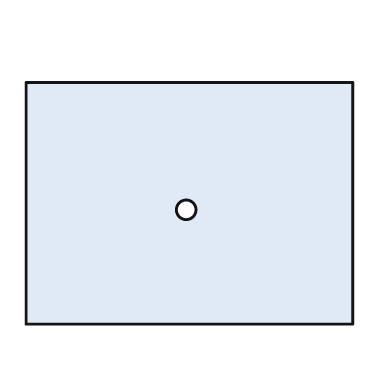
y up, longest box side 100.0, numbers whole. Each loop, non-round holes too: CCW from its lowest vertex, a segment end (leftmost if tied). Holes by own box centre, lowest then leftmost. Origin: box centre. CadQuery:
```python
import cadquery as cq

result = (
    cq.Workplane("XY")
    .moveTo(-50.0, -37.0)
    .lineTo(50.0, -37.0)
    .lineTo(50.0, 37.0)
    .lineTo(-50.0, 37.0)
    .close()
    .moveTo(-1.0, -2.0)
    .circle(3.0)
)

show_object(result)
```